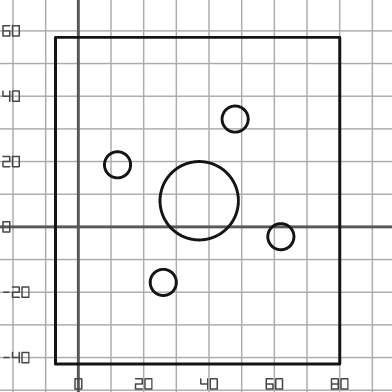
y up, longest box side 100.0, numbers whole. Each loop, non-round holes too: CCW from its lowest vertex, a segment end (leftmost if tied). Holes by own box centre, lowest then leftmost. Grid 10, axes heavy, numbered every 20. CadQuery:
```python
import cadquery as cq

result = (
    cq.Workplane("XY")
    .moveTo(-7.0, -42.0)
    .lineTo(80.0, -42.0)
    .lineTo(80.0, 58.0)
    .lineTo(-7.0, 58.0)
    .close()
    .moveTo(26.0, -17.0)
    .circle(4.0)
    .moveTo(62.0, -3.0)
    .circle(4.0)
    .moveTo(37.0, 8.0)
    .circle(12.0)
    .moveTo(12.0, 19.0)
    .circle(4.0)
    .moveTo(48.0, 33.0)
    .circle(4.0)
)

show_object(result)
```